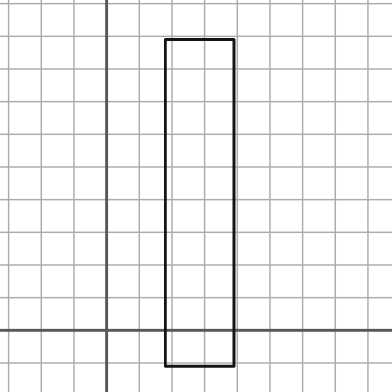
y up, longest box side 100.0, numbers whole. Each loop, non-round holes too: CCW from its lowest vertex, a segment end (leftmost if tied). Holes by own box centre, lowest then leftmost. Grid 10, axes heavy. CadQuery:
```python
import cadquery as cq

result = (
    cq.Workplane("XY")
    .moveTo(18.0, -11.0)
    .lineTo(39.0, -11.0)
    .lineTo(39.0, 89.0)
    .lineTo(18.0, 89.0)
    .close()
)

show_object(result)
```